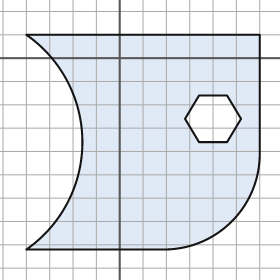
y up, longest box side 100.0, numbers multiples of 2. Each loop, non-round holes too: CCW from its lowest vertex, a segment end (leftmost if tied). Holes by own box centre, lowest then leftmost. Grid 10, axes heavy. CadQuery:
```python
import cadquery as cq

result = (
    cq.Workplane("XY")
    .moveTo(-40.0, -82.0)
    .lineTo(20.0, -82.0)
    .threePointArc((48.0, -70.0), (60.0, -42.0))
    .lineTo(60.0, 10.0)
    .lineTo(-40.0, 10.0)
    .threePointArc((-16.0, -36.0), (-40.0, -82.0))
    .close()
    .moveTo(34.0, -36.0)
    .lineTo(46.0, -36.0)
    .lineTo(52.0, -26.0)
    .lineTo(46.0, -16.0)
    .lineTo(34.0, -16.0)
    .lineTo(28.0, -26.0)
    .close()
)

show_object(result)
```